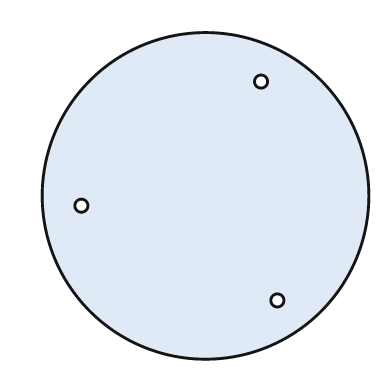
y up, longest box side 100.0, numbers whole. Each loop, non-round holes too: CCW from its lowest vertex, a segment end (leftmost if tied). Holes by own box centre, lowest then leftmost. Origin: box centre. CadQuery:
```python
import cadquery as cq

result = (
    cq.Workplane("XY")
    .moveTo(0.0, 0.0)
    .circle(50.0)
    .moveTo(22.0, -32.0)
    .circle(2.0)
    .moveTo(-38.0, -3.0)
    .circle(2.0)
    .moveTo(17.0, 35.0)
    .circle(2.0)
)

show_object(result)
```